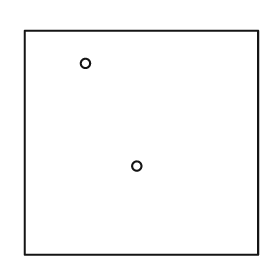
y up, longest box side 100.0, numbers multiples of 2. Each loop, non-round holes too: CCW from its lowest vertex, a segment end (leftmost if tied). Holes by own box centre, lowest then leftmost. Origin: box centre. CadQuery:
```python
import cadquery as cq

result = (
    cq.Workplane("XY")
    .moveTo(-50.0, -48.0)
    .lineTo(50.0, -48.0)
    .lineTo(50.0, 48.0)
    .lineTo(-50.0, 48.0)
    .close()
    .moveTo(-2.0, -10.0)
    .circle(2.0)
    .moveTo(-24.0, 34.0)
    .circle(2.0)
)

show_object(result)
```